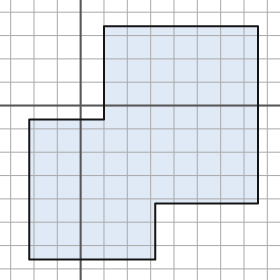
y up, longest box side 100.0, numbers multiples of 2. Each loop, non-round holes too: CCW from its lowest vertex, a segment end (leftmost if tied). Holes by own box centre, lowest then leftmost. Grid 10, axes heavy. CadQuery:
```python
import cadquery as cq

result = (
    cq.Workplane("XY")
    .moveTo(-22.0, -66.0)
    .lineTo(32.0, -66.0)
    .lineTo(32.0, -42.0)
    .lineTo(76.0, -42.0)
    .lineTo(76.0, 34.0)
    .lineTo(10.0, 34.0)
    .lineTo(10.0, -6.0)
    .lineTo(-22.0, -6.0)
    .close()
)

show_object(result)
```